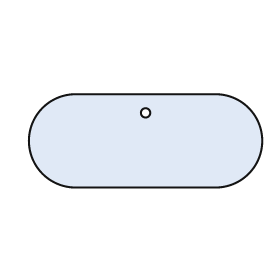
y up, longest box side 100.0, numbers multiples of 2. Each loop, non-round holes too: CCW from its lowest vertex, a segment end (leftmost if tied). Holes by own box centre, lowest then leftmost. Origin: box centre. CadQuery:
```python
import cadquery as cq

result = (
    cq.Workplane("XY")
    .moveTo(-30.0, -20.0)
    .lineTo(30.0, -20.0)
    .threePointArc((50.0, 0.0), (30.0, 20.0))
    .lineTo(-30.0, 20.0)
    .threePointArc((-50.0, 0.0), (-30.0, -20.0))
    .close()
    .moveTo(0.0, 12.0)
    .circle(2.0)
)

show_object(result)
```